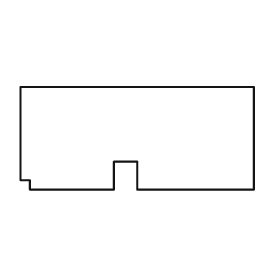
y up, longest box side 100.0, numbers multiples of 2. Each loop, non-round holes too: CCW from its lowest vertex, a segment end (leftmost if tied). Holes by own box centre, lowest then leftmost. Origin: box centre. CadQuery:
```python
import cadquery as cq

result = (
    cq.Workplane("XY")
    .moveTo(-46.0, -22.0)
    .lineTo(-10.0, -22.0)
    .lineTo(-10.0, -10.0)
    .lineTo(0.0, -10.0)
    .lineTo(0.0, -22.0)
    .lineTo(50.0, -22.0)
    .lineTo(50.0, 22.0)
    .lineTo(-50.0, 22.0)
    .lineTo(-50.0, -18.0)
    .lineTo(-46.0, -18.0)
    .close()
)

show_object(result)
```